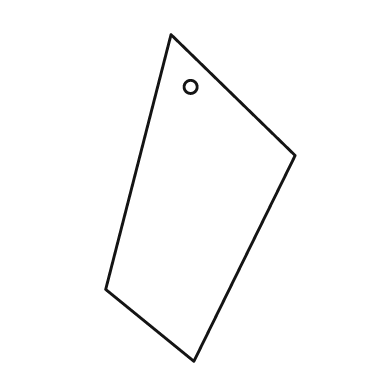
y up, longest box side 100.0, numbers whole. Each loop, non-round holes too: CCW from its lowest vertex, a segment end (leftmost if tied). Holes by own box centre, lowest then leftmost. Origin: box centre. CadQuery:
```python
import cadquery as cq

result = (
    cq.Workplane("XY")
    .moveTo(-2.0, -50.0)
    .lineTo(29.0, 13.0)
    .lineTo(-9.0, 50.0)
    .lineTo(-29.0, -28.0)
    .close()
    .moveTo(-3.0, 34.0)
    .circle(2.0)
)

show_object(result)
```